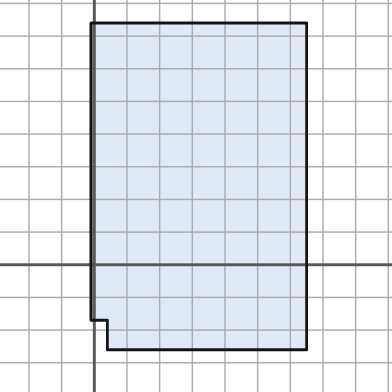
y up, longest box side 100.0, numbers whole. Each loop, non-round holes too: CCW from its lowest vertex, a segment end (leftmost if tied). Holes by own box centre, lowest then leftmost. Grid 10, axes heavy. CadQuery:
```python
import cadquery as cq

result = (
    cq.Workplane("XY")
    .moveTo(4.0, -26.0)
    .lineTo(65.0, -26.0)
    .lineTo(65.0, 74.0)
    .lineTo(-1.0, 74.0)
    .lineTo(-1.0, -17.0)
    .lineTo(4.0, -17.0)
    .close()
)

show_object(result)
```